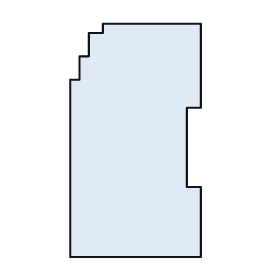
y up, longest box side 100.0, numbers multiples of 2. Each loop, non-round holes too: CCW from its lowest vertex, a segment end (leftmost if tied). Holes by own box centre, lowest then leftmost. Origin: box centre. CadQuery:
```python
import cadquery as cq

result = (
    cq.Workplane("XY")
    .moveTo(-28.0, -50.0)
    .lineTo(28.0, -50.0)
    .lineTo(28.0, -20.0)
    .lineTo(22.0, -20.0)
    .lineTo(22.0, 14.0)
    .lineTo(28.0, 14.0)
    .lineTo(28.0, 50.0)
    .lineTo(-14.0, 50.0)
    .lineTo(-14.0, 46.0)
    .lineTo(-20.0, 46.0)
    .lineTo(-20.0, 36.0)
    .lineTo(-24.0, 36.0)
    .lineTo(-24.0, 26.0)
    .lineTo(-28.0, 26.0)
    .close()
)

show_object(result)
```